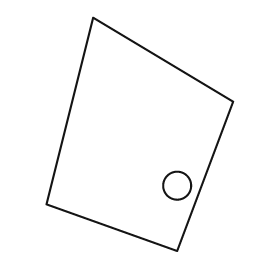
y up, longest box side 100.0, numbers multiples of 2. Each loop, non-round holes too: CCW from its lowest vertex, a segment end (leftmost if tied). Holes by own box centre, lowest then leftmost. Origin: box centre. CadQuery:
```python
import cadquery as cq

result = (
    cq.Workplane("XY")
    .moveTo(16.0, -50.0)
    .lineTo(40.0, 14.0)
    .lineTo(-20.0, 50.0)
    .lineTo(-40.0, -30.0)
    .close()
    .moveTo(16.0, -22.0)
    .circle(6.0)
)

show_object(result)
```